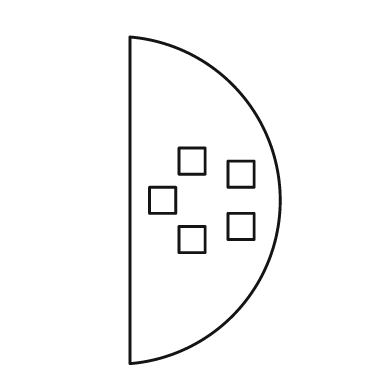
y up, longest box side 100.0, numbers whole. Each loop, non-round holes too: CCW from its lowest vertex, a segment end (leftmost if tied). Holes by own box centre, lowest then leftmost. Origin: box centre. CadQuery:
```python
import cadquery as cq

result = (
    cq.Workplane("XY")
    .moveTo(-23.0, -50.0)
    .threePointArc((23.0, 0.0), (-23.0, 50.0))
    .close()
    .moveTo(-8.0, -16.0)
    .lineTo(0.0, -16.0)
    .lineTo(0.0, -8.0)
    .lineTo(-8.0, -8.0)
    .close()
    .moveTo(7.0, -12.0)
    .lineTo(15.0, -12.0)
    .lineTo(15.0, -4.0)
    .lineTo(7.0, -4.0)
    .close()
    .moveTo(-17.0, -4.0)
    .lineTo(-9.0, -4.0)
    .lineTo(-9.0, 4.0)
    .lineTo(-17.0, 4.0)
    .close()
    .moveTo(7.0, 4.0)
    .lineTo(15.0, 4.0)
    .lineTo(15.0, 12.0)
    .lineTo(7.0, 12.0)
    .close()
    .moveTo(-8.0, 8.0)
    .lineTo(0.0, 8.0)
    .lineTo(0.0, 16.0)
    .lineTo(-8.0, 16.0)
    .close()
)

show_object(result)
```